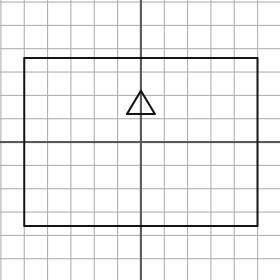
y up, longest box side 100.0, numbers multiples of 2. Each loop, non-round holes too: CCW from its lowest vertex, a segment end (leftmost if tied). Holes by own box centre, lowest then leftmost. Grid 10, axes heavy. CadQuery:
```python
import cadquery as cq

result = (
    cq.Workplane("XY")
    .moveTo(-50.0, -36.0)
    .lineTo(50.0, -36.0)
    .lineTo(50.0, 36.0)
    .lineTo(-50.0, 36.0)
    .close()
    .moveTo(-6.0, 12.0)
    .lineTo(6.0, 12.0)
    .lineTo(0.0, 22.0)
    .close()
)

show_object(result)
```